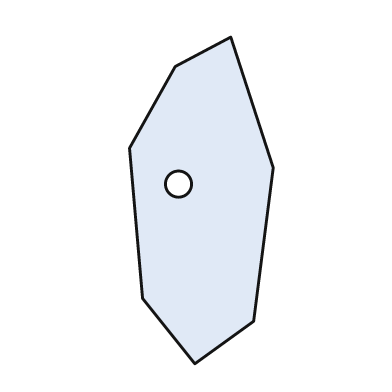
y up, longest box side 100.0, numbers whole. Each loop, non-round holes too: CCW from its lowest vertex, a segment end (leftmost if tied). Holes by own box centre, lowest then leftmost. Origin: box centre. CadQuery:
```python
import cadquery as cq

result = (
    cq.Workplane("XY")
    .moveTo(-2.0, -50.0)
    .lineTo(16.0, -37.0)
    .lineTo(22.0, 10.0)
    .lineTo(9.0, 50.0)
    .lineTo(-8.0, 41.0)
    .lineTo(-22.0, 16.0)
    .lineTo(-18.0, -30.0)
    .close()
    .moveTo(-7.0, 5.0)
    .circle(4.0)
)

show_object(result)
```